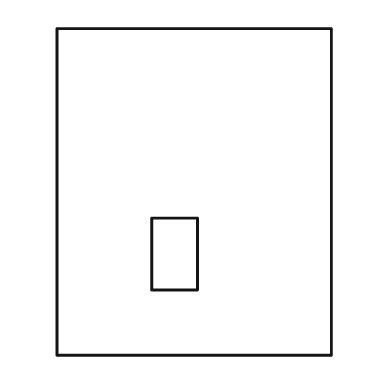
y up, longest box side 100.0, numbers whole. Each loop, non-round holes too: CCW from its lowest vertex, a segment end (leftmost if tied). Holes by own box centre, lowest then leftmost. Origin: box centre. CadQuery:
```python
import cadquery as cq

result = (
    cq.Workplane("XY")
    .moveTo(-42.0, -50.0)
    .lineTo(42.0, -50.0)
    .lineTo(42.0, 50.0)
    .lineTo(-42.0, 50.0)
    .close()
    .moveTo(-13.0, -30.0)
    .lineTo(1.0, -30.0)
    .lineTo(1.0, -8.0)
    .lineTo(-13.0, -8.0)
    .close()
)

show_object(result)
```